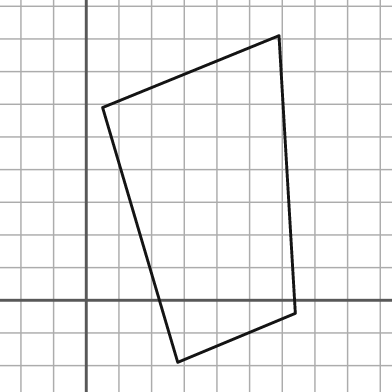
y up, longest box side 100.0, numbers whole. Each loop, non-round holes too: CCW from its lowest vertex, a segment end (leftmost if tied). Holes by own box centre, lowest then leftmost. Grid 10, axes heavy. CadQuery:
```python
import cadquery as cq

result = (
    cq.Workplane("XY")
    .moveTo(28.0, -19.0)
    .lineTo(64.0, -4.0)
    .lineTo(59.0, 81.0)
    .lineTo(5.0, 59.0)
    .close()
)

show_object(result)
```